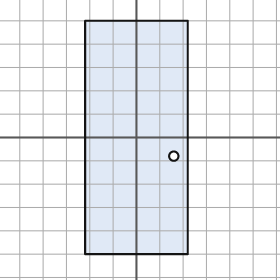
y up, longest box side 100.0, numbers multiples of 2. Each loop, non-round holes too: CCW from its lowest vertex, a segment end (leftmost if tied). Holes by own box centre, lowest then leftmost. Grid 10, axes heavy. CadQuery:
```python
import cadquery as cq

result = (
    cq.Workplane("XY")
    .moveTo(-22.0, -50.0)
    .lineTo(22.0, -50.0)
    .lineTo(22.0, 50.0)
    .lineTo(-22.0, 50.0)
    .close()
    .moveTo(16.0, -8.0)
    .circle(2.0)
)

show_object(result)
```